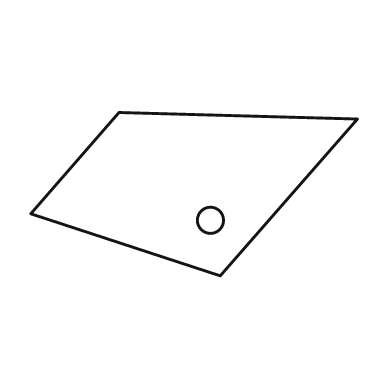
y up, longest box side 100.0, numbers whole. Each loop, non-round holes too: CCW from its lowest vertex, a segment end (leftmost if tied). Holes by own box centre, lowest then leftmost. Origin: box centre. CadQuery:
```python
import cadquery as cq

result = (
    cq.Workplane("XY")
    .moveTo(8.0, -25.0)
    .lineTo(50.0, 23.0)
    .lineTo(-23.0, 25.0)
    .lineTo(-50.0, -6.0)
    .close()
    .moveTo(5.0, -8.0)
    .circle(4.0)
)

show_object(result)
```